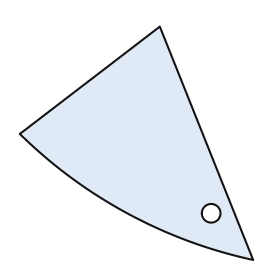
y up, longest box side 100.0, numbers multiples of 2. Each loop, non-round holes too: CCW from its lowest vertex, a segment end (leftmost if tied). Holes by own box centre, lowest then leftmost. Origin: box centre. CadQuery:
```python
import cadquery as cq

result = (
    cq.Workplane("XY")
    .moveTo(50.0, -50.0)
    .lineTo(10.0, 50.0)
    .lineTo(-50.0, 4.0)
    .threePointArc((-4.0, -30.0), (50.0, -50.0))
    .close()
    .moveTo(32.0, -30.0)
    .circle(4.0)
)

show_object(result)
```